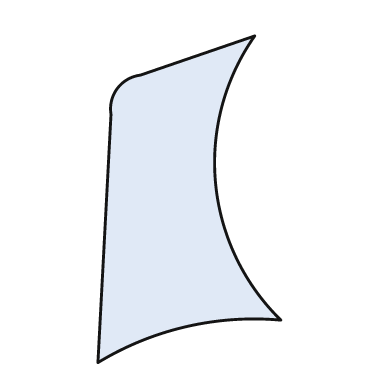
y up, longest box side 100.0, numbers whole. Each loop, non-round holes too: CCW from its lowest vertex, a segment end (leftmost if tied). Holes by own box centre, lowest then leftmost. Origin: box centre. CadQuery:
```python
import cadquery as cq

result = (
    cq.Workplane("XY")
    .moveTo(-28.0, -50.0)
    .threePointArc((-1.0, -39.0), (28.0, -37.0))
    .threePointArc((8.0, 5.0), (20.0, 50.0))
    .lineTo(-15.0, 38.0)
    .threePointArc((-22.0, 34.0), (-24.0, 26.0))
    .close()
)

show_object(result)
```